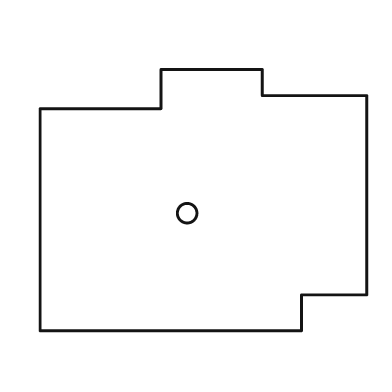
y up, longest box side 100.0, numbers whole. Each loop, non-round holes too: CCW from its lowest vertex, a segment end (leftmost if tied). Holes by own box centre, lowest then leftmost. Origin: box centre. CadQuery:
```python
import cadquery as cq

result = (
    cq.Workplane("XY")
    .moveTo(-50.0, -40.0)
    .lineTo(30.0, -40.0)
    .lineTo(30.0, -29.0)
    .lineTo(50.0, -29.0)
    .lineTo(50.0, 32.0)
    .lineTo(18.0, 32.0)
    .lineTo(18.0, 40.0)
    .lineTo(-13.0, 40.0)
    .lineTo(-13.0, 28.0)
    .lineTo(-50.0, 28.0)
    .close()
    .moveTo(-5.0, -4.0)
    .circle(3.0)
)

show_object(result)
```